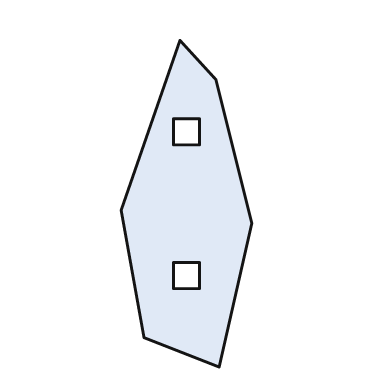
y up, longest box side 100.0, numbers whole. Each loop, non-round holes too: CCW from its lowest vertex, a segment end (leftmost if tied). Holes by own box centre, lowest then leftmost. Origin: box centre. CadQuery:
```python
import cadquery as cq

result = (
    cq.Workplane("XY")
    .moveTo(10.0, -50.0)
    .lineTo(20.0, -6.0)
    .lineTo(9.0, 38.0)
    .lineTo(-2.0, 50.0)
    .lineTo(-20.0, -2.0)
    .lineTo(-13.0, -41.0)
    .close()
    .moveTo(-4.0, -26.0)
    .lineTo(4.0, -26.0)
    .lineTo(4.0, -18.0)
    .lineTo(-4.0, -18.0)
    .close()
    .moveTo(-4.0, 18.0)
    .lineTo(4.0, 18.0)
    .lineTo(4.0, 26.0)
    .lineTo(-4.0, 26.0)
    .close()
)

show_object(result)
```